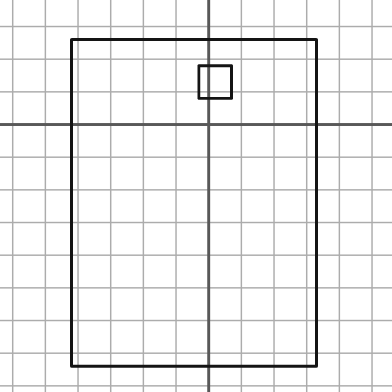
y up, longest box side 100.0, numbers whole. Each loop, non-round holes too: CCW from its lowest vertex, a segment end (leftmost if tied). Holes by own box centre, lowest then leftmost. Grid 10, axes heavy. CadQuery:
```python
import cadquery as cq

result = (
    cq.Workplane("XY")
    .moveTo(-42.0, -74.0)
    .lineTo(33.0, -74.0)
    .lineTo(33.0, 26.0)
    .lineTo(-42.0, 26.0)
    .close()
    .moveTo(-3.0, 8.0)
    .lineTo(7.0, 8.0)
    .lineTo(7.0, 18.0)
    .lineTo(-3.0, 18.0)
    .close()
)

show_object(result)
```